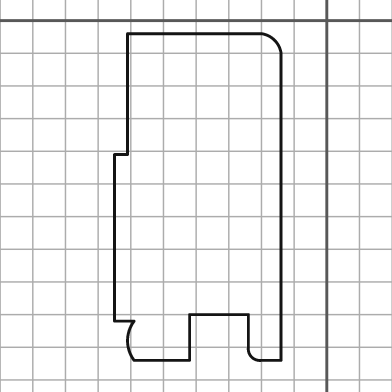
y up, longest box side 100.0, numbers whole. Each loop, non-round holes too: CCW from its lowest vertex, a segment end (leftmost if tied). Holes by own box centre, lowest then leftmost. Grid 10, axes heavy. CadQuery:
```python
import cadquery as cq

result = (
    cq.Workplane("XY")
    .moveTo(-59.0, -104.0)
    .lineTo(-42.0, -104.0)
    .lineTo(-42.0, -90.0)
    .lineTo(-24.0, -90.0)
    .lineTo(-24.0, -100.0)
    .threePointArc((-23.0, -103.0), (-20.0, -104.0))
    .lineTo(-14.0, -104.0)
    .lineTo(-14.0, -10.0)
    .threePointArc((-16.0, -6.0), (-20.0, -4.0))
    .lineTo(-61.0, -4.0)
    .lineTo(-61.0, -41.0)
    .lineTo(-65.0, -41.0)
    .lineTo(-65.0, -92.0)
    .lineTo(-59.0, -92.0)
    .threePointArc((-61.0, -98.0), (-59.0, -104.0))
    .close()
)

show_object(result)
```